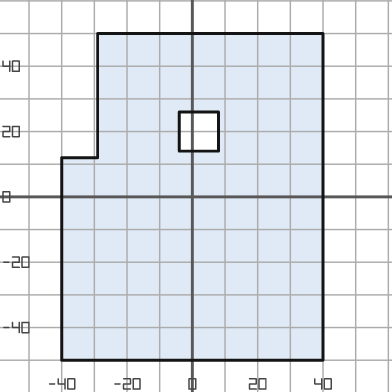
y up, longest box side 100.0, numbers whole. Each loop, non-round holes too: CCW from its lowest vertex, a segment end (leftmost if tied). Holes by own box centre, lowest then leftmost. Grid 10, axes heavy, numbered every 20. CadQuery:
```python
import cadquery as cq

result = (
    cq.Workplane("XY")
    .moveTo(-40.0, -50.0)
    .lineTo(40.0, -50.0)
    .lineTo(40.0, 50.0)
    .lineTo(-29.0, 50.0)
    .lineTo(-29.0, 12.0)
    .lineTo(-40.0, 12.0)
    .close()
    .moveTo(-4.0, 14.0)
    .lineTo(8.0, 14.0)
    .lineTo(8.0, 26.0)
    .lineTo(-4.0, 26.0)
    .close()
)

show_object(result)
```